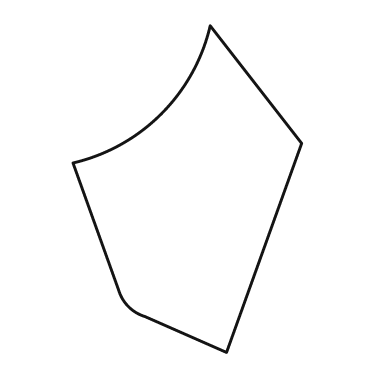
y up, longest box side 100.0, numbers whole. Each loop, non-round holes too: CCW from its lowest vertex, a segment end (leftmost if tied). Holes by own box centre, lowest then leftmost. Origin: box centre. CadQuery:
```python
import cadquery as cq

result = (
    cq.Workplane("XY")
    .moveTo(12.0, -50.0)
    .lineTo(35.0, 14.0)
    .lineTo(7.0, 50.0)
    .threePointArc((-8.0, 23.0), (-35.0, 8.0))
    .lineTo(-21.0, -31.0)
    .threePointArc((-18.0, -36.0), (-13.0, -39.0))
    .close()
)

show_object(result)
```